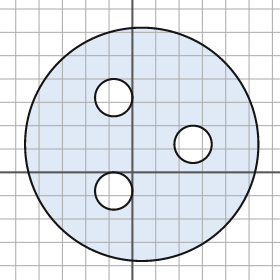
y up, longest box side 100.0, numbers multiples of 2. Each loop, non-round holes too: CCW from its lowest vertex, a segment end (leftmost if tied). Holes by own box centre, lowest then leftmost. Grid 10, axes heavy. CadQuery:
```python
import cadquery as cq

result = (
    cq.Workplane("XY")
    .moveTo(4.0, 12.0)
    .circle(50.0)
    .moveTo(-8.0, -8.0)
    .circle(8.0)
    .moveTo(26.0, 12.0)
    .circle(8.0)
    .moveTo(-8.0, 32.0)
    .circle(8.0)
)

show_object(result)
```